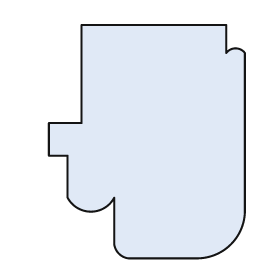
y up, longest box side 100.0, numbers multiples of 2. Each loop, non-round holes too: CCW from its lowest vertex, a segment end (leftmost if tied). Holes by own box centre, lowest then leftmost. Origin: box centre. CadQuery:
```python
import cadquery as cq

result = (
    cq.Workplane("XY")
    .moveTo(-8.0, -50.0)
    .lineTo(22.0, -50.0)
    .threePointArc((36.0, -44.0), (42.0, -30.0))
    .lineTo(42.0, 38.0)
    .threePointArc((38.0, 40.0), (34.0, 38.0))
    .lineTo(34.0, 50.0)
    .lineTo(-28.0, 50.0)
    .lineTo(-28.0, 8.0)
    .lineTo(-42.0, 8.0)
    .lineTo(-42.0, -6.0)
    .lineTo(-34.0, -6.0)
    .lineTo(-34.0, -24.0)
    .threePointArc((-24.0, -30.0), (-14.0, -24.0))
    .lineTo(-14.0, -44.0)
    .threePointArc((-12.0, -48.0), (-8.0, -50.0))
    .close()
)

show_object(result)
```